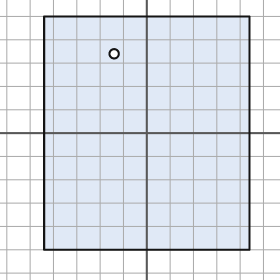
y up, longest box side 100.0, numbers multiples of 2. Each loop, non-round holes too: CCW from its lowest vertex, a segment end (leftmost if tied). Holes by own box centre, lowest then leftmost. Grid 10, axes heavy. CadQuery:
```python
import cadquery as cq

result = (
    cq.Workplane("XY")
    .moveTo(-44.0, -50.0)
    .lineTo(44.0, -50.0)
    .lineTo(44.0, 50.0)
    .lineTo(-44.0, 50.0)
    .close()
    .moveTo(-14.0, 34.0)
    .circle(2.0)
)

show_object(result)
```